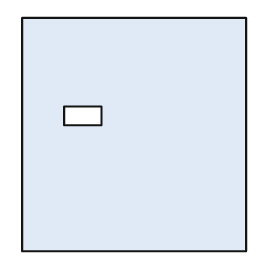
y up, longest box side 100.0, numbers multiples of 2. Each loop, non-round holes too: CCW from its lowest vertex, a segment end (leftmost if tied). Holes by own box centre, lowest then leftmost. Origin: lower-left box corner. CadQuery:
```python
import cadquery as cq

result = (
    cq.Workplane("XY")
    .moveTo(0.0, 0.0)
    .lineTo(96.0, 0.0)
    .lineTo(96.0, 100.0)
    .lineTo(0.0, 100.0)
    .close()
    .moveTo(18.0, 54.0)
    .lineTo(34.0, 54.0)
    .lineTo(34.0, 62.0)
    .lineTo(18.0, 62.0)
    .close()
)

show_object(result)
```